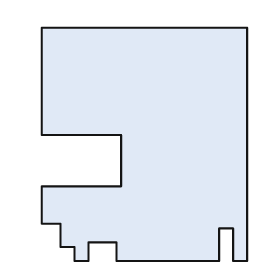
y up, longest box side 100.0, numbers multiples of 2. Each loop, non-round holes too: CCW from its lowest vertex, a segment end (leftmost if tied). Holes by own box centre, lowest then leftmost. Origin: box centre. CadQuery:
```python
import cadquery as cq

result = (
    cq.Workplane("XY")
    .moveTo(-30.0, -50.0)
    .lineTo(-24.0, -50.0)
    .lineTo(-24.0, -42.0)
    .lineTo(-12.0, -42.0)
    .lineTo(-12.0, -50.0)
    .lineTo(32.0, -50.0)
    .lineTo(32.0, -36.0)
    .lineTo(38.0, -36.0)
    .lineTo(38.0, -50.0)
    .lineTo(44.0, -50.0)
    .lineTo(44.0, 50.0)
    .lineTo(-44.0, 50.0)
    .lineTo(-44.0, 4.0)
    .lineTo(-10.0, 4.0)
    .lineTo(-10.0, -18.0)
    .lineTo(-44.0, -18.0)
    .lineTo(-44.0, -34.0)
    .lineTo(-36.0, -34.0)
    .lineTo(-36.0, -44.0)
    .lineTo(-30.0, -44.0)
    .close()
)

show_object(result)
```